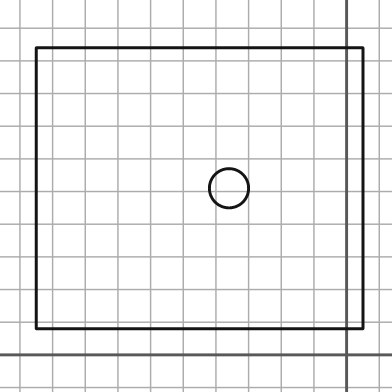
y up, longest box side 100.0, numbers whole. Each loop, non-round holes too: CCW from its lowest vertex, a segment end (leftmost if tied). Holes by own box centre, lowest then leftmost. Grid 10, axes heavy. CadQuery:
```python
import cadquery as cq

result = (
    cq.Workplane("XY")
    .moveTo(-95.0, 8.0)
    .lineTo(5.0, 8.0)
    .lineTo(5.0, 94.0)
    .lineTo(-95.0, 94.0)
    .close()
    .moveTo(-36.0, 51.0)
    .circle(6.0)
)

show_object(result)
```